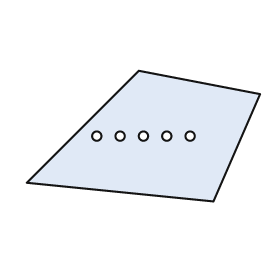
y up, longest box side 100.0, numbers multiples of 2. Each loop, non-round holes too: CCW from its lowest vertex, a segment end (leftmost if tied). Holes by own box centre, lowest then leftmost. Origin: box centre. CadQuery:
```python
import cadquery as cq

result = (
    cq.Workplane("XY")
    .moveTo(30.0, -28.0)
    .lineTo(50.0, 18.0)
    .lineTo(-2.0, 28.0)
    .lineTo(-50.0, -20.0)
    .close()
    .moveTo(-20.0, 0.0)
    .circle(2.0)
    .moveTo(-10.0, 0.0)
    .circle(2.0)
    .moveTo(0.0, 0.0)
    .circle(2.0)
    .moveTo(10.0, 0.0)
    .circle(2.0)
    .moveTo(20.0, 0.0)
    .circle(2.0)
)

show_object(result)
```